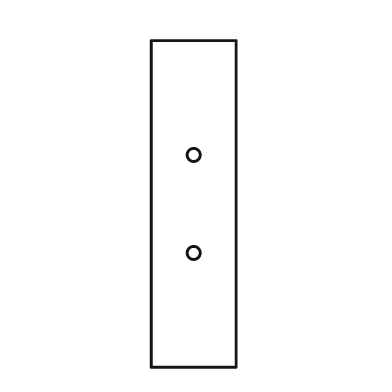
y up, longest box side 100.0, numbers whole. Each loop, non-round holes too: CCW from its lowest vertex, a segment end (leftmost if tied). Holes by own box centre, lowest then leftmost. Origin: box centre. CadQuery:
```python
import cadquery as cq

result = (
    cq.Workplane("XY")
    .moveTo(-13.0, -50.0)
    .lineTo(13.0, -50.0)
    .lineTo(13.0, 50.0)
    .lineTo(-13.0, 50.0)
    .close()
    .moveTo(0.0, -15.0)
    .circle(2.0)
    .moveTo(0.0, 15.0)
    .circle(2.0)
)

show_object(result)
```